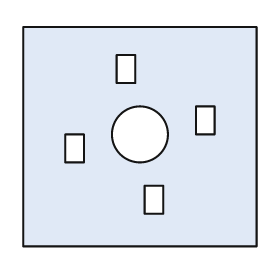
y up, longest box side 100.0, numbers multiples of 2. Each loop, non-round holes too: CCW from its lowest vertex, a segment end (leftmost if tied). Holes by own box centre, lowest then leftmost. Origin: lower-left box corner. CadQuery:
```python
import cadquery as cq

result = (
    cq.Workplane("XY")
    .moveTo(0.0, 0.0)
    .lineTo(100.0, 0.0)
    .lineTo(100.0, 94.0)
    .lineTo(0.0, 94.0)
    .close()
    .moveTo(52.0, 14.0)
    .lineTo(60.0, 14.0)
    .lineTo(60.0, 26.0)
    .lineTo(52.0, 26.0)
    .close()
    .moveTo(18.0, 36.0)
    .lineTo(26.0, 36.0)
    .lineTo(26.0, 48.0)
    .lineTo(18.0, 48.0)
    .close()
    .moveTo(50.0, 48.0)
    .circle(12.0)
    .moveTo(74.0, 48.0)
    .lineTo(82.0, 48.0)
    .lineTo(82.0, 60.0)
    .lineTo(74.0, 60.0)
    .close()
    .moveTo(40.0, 70.0)
    .lineTo(48.0, 70.0)
    .lineTo(48.0, 82.0)
    .lineTo(40.0, 82.0)
    .close()
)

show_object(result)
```